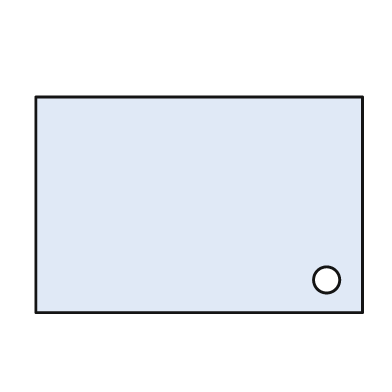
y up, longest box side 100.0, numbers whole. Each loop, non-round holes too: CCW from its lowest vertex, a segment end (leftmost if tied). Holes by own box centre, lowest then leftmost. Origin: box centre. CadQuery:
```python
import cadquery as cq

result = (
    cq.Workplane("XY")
    .moveTo(-50.0, -33.0)
    .lineTo(50.0, -33.0)
    .lineTo(50.0, 33.0)
    .lineTo(-50.0, 33.0)
    .close()
    .moveTo(39.0, -23.0)
    .circle(4.0)
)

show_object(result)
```